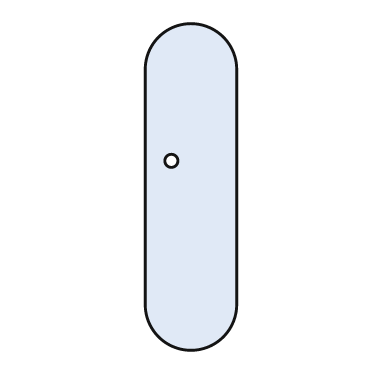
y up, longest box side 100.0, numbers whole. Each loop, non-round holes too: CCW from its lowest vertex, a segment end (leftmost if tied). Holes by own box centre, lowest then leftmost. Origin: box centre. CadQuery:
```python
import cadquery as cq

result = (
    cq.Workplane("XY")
    .moveTo(-14.0, -36.0)
    .threePointArc((0.0, -50.0), (14.0, -36.0))
    .lineTo(14.0, 36.0)
    .threePointArc((0.0, 50.0), (-14.0, 36.0))
    .close()
    .moveTo(-6.0, 8.0)
    .circle(2.0)
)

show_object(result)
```